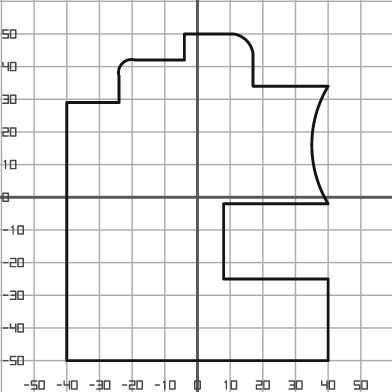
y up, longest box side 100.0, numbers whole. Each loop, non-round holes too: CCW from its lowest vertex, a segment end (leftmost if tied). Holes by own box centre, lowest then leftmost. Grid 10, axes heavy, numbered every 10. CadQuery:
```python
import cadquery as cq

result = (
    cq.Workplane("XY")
    .moveTo(-40.0, -50.0)
    .lineTo(40.0, -50.0)
    .lineTo(40.0, -25.0)
    .lineTo(8.0, -25.0)
    .lineTo(8.0, -2.0)
    .lineTo(40.0, -2.0)
    .threePointArc((35.0, 16.0), (40.0, 34.0))
    .lineTo(17.0, 34.0)
    .lineTo(17.0, 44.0)
    .threePointArc((15.0, 48.0), (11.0, 50.0))
    .lineTo(-4.0, 50.0)
    .lineTo(-4.0, 42.0)
    .lineTo(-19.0, 42.0)
    .threePointArc((-23.0, 41.0), (-24.0, 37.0))
    .lineTo(-24.0, 29.0)
    .lineTo(-40.0, 29.0)
    .close()
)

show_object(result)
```